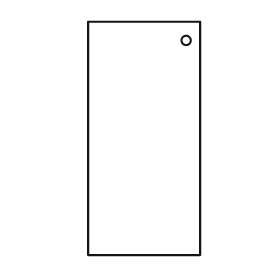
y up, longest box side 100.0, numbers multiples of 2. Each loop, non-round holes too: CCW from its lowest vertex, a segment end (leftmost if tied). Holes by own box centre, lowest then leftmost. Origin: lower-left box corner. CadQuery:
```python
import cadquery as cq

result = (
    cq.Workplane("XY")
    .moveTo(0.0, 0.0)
    .lineTo(48.0, 0.0)
    .lineTo(48.0, 100.0)
    .lineTo(0.0, 100.0)
    .close()
    .moveTo(42.0, 92.0)
    .circle(2.0)
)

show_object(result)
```